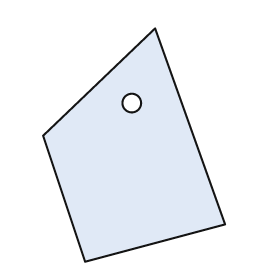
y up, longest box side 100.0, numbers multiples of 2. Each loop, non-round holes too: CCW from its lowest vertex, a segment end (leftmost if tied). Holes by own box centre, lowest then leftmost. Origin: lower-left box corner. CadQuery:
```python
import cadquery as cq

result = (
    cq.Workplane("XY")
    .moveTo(18.0, 0.0)
    .lineTo(78.0, 16.0)
    .lineTo(48.0, 100.0)
    .lineTo(0.0, 54.0)
    .close()
    .moveTo(38.0, 68.0)
    .circle(4.0)
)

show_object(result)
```